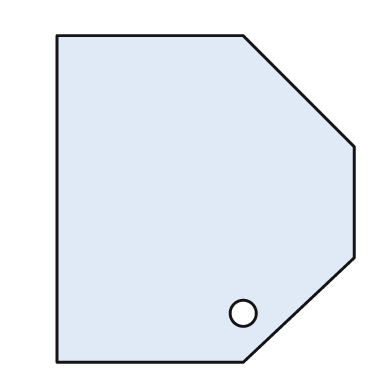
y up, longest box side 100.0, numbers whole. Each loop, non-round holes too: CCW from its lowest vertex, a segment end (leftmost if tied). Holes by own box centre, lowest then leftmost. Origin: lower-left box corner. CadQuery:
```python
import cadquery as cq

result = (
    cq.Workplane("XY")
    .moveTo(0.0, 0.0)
    .lineTo(57.0, 0.0)
    .lineTo(91.0, 32.0)
    .lineTo(91.0, 66.0)
    .lineTo(57.0, 100.0)
    .lineTo(0.0, 100.0)
    .close()
    .moveTo(57.0, 15.0)
    .circle(4.0)
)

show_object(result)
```